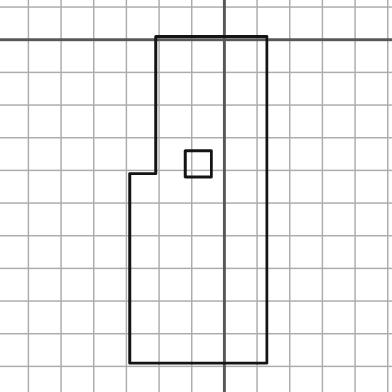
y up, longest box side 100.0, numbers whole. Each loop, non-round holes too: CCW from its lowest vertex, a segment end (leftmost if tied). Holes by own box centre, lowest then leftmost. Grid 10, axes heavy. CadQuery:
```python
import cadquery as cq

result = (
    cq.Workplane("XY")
    .moveTo(-29.0, -99.0)
    .lineTo(13.0, -99.0)
    .lineTo(13.0, 1.0)
    .lineTo(-21.0, 1.0)
    .lineTo(-21.0, -41.0)
    .lineTo(-29.0, -41.0)
    .close()
    .moveTo(-12.0, -42.0)
    .lineTo(-4.0, -42.0)
    .lineTo(-4.0, -34.0)
    .lineTo(-12.0, -34.0)
    .close()
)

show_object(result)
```